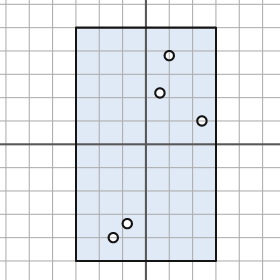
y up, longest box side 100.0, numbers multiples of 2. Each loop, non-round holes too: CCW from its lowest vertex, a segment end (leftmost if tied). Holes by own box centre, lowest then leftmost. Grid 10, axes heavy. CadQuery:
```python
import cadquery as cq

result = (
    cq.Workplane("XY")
    .moveTo(-30.0, -50.0)
    .lineTo(30.0, -50.0)
    .lineTo(30.0, 50.0)
    .lineTo(-30.0, 50.0)
    .close()
    .moveTo(-14.0, -40.0)
    .circle(2.0)
    .moveTo(-8.0, -34.0)
    .circle(2.0)
    .moveTo(24.0, 10.0)
    .circle(2.0)
    .moveTo(6.0, 22.0)
    .circle(2.0)
    .moveTo(10.0, 38.0)
    .circle(2.0)
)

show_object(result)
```